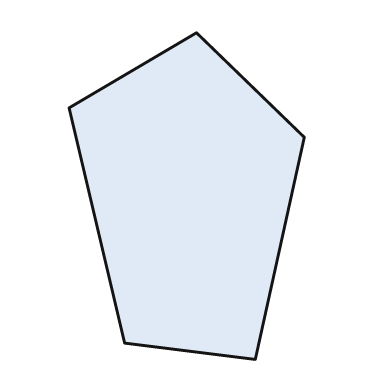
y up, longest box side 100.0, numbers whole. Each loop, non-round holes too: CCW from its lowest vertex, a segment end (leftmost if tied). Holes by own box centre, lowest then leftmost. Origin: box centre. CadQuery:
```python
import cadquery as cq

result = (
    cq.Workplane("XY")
    .moveTo(21.0, -50.0)
    .lineTo(36.0, 18.0)
    .lineTo(3.0, 50.0)
    .lineTo(-36.0, 27.0)
    .lineTo(-19.0, -45.0)
    .close()
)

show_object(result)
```